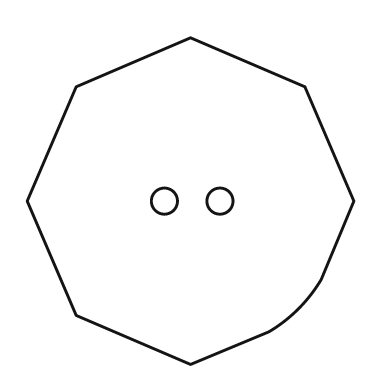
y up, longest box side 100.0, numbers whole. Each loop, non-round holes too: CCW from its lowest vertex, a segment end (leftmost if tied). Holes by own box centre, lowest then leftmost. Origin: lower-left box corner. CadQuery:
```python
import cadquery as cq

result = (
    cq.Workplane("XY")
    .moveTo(50.0, 0.0)
    .lineTo(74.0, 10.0)
    .threePointArc((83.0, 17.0), (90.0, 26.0))
    .lineTo(100.0, 50.0)
    .lineTo(85.0, 85.0)
    .lineTo(50.0, 100.0)
    .lineTo(15.0, 85.0)
    .lineTo(0.0, 50.0)
    .lineTo(15.0, 15.0)
    .close()
    .moveTo(42.0, 50.0)
    .circle(4.0)
    .moveTo(59.0, 50.0)
    .circle(4.0)
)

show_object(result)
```